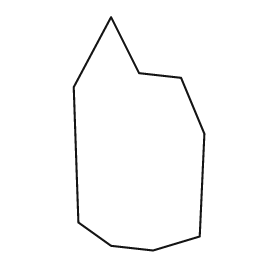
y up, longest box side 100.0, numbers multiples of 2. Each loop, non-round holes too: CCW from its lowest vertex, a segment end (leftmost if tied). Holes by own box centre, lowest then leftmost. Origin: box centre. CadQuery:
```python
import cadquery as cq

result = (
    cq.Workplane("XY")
    .moveTo(6.0, -50.0)
    .lineTo(26.0, -44.0)
    .lineTo(28.0, 0.0)
    .lineTo(18.0, 24.0)
    .lineTo(0.0, 26.0)
    .lineTo(-12.0, 50.0)
    .lineTo(-28.0, 20.0)
    .lineTo(-26.0, -38.0)
    .lineTo(-12.0, -48.0)
    .close()
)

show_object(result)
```